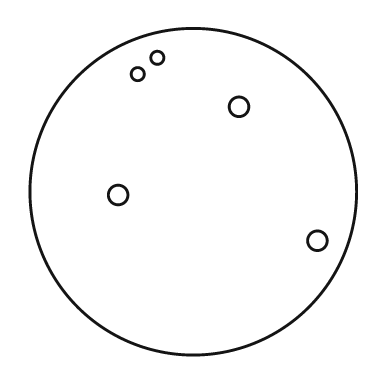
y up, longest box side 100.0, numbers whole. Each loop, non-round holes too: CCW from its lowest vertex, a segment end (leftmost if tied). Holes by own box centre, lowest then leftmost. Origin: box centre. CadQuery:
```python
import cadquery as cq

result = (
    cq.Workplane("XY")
    .moveTo(0.0, 0.0)
    .circle(50.0)
    .moveTo(38.0, -15.0)
    .circle(3.0)
    .moveTo(-23.0, -1.0)
    .circle(3.0)
    .moveTo(14.0, 26.0)
    .circle(3.0)
    .moveTo(-17.0, 36.0)
    .circle(2.0)
    .moveTo(-11.0, 41.0)
    .circle(2.0)
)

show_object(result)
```